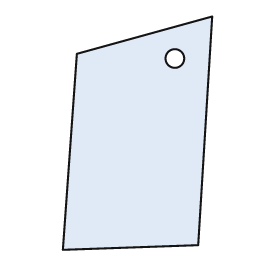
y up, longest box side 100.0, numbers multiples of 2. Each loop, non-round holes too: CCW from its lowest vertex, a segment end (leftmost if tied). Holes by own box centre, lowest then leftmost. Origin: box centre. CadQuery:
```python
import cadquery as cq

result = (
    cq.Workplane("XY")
    .moveTo(-32.0, -50.0)
    .lineTo(26.0, -48.0)
    .lineTo(32.0, 50.0)
    .lineTo(-26.0, 34.0)
    .close()
    .moveTo(16.0, 32.0)
    .circle(4.0)
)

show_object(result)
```